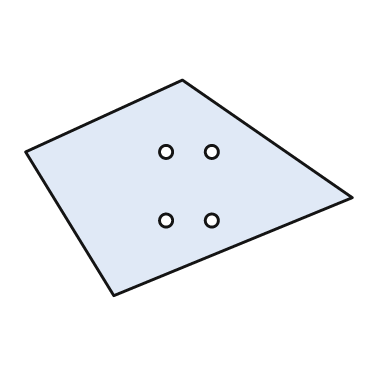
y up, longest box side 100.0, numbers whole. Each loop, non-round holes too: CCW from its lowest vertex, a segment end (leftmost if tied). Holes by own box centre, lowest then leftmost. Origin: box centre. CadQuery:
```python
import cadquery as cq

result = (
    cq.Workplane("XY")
    .moveTo(-23.0, -33.0)
    .lineTo(50.0, -3.0)
    .lineTo(-2.0, 33.0)
    .lineTo(-50.0, 11.0)
    .close()
    .moveTo(-7.0, -10.0)
    .circle(2.0)
    .moveTo(7.0, -10.0)
    .circle(2.0)
    .moveTo(-7.0, 11.0)
    .circle(2.0)
    .moveTo(7.0, 11.0)
    .circle(2.0)
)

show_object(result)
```